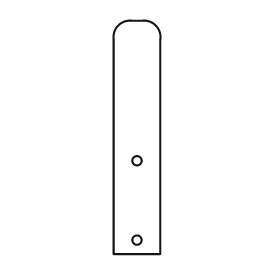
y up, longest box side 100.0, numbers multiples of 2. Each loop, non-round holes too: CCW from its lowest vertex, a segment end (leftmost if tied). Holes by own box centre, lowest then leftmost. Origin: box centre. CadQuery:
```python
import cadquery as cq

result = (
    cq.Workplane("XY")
    .moveTo(-10.0, -50.0)
    .lineTo(10.0, -50.0)
    .lineTo(10.0, 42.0)
    .threePointArc((8.0, 48.0), (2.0, 50.0))
    .lineTo(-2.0, 50.0)
    .threePointArc((-8.0, 48.0), (-10.0, 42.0))
    .close()
    .moveTo(0.0, -44.0)
    .circle(2.0)
    .moveTo(0.0, -10.0)
    .circle(2.0)
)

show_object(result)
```